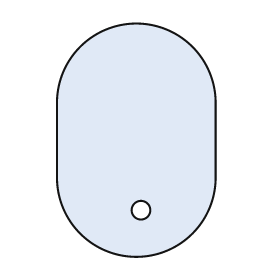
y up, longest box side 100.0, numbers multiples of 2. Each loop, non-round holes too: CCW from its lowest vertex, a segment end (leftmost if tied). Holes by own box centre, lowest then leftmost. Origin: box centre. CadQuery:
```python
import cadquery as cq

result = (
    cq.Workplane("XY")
    .moveTo(-34.0, -16.0)
    .threePointArc((0.0, -50.0), (34.0, -16.0))
    .lineTo(34.0, 16.0)
    .threePointArc((0.0, 50.0), (-34.0, 16.0))
    .close()
    .moveTo(2.0, -30.0)
    .circle(4.0)
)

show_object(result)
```